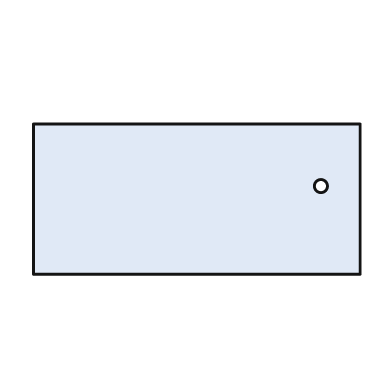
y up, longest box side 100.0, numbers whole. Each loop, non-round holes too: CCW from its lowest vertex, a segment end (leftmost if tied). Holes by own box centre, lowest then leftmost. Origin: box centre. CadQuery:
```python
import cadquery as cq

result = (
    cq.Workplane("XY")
    .moveTo(-50.0, -23.0)
    .lineTo(50.0, -23.0)
    .lineTo(50.0, 23.0)
    .lineTo(-50.0, 23.0)
    .close()
    .moveTo(38.0, 4.0)
    .circle(2.0)
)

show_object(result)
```